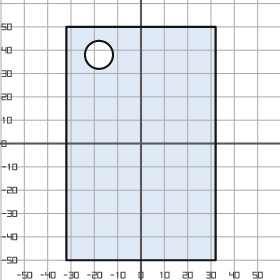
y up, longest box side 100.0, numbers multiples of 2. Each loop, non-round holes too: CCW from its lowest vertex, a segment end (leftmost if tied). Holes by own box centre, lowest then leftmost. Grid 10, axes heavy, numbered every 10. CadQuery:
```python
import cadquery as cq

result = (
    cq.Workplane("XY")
    .moveTo(-32.0, -50.0)
    .lineTo(32.0, -50.0)
    .lineTo(32.0, 50.0)
    .lineTo(-32.0, 50.0)
    .close()
    .moveTo(-18.0, 38.0)
    .circle(6.0)
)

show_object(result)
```